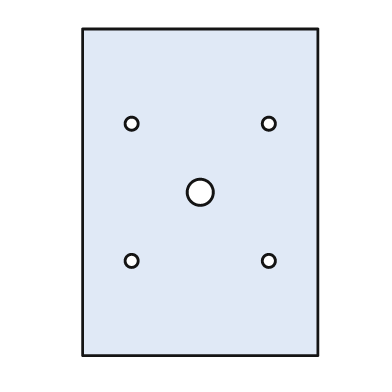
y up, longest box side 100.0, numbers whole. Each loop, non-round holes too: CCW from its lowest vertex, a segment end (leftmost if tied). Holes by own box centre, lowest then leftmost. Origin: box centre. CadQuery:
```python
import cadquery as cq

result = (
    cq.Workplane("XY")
    .moveTo(-36.0, -50.0)
    .lineTo(36.0, -50.0)
    .lineTo(36.0, 50.0)
    .lineTo(-36.0, 50.0)
    .close()
    .moveTo(-21.0, -21.0)
    .circle(2.0)
    .moveTo(21.0, -21.0)
    .circle(2.0)
    .moveTo(0.0, 0.0)
    .circle(4.0)
    .moveTo(-21.0, 21.0)
    .circle(2.0)
    .moveTo(21.0, 21.0)
    .circle(2.0)
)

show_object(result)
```